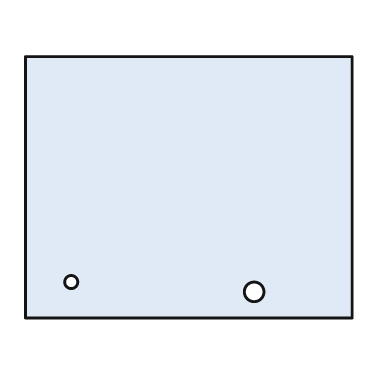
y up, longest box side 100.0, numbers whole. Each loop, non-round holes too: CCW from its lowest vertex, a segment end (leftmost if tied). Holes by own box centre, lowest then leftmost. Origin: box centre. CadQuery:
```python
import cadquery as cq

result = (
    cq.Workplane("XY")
    .moveTo(-50.0, -40.0)
    .lineTo(50.0, -40.0)
    .lineTo(50.0, 40.0)
    .lineTo(-50.0, 40.0)
    .close()
    .moveTo(20.0, -32.0)
    .circle(3.0)
    .moveTo(-36.0, -29.0)
    .circle(2.0)
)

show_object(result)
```